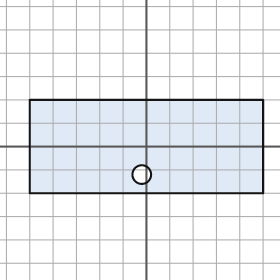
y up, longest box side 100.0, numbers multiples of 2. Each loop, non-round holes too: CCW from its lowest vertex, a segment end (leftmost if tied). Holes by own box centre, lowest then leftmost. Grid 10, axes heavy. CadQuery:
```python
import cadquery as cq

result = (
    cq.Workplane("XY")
    .moveTo(-50.0, -20.0)
    .lineTo(50.0, -20.0)
    .lineTo(50.0, 20.0)
    .lineTo(-50.0, 20.0)
    .close()
    .moveTo(-2.0, -12.0)
    .circle(4.0)
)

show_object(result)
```